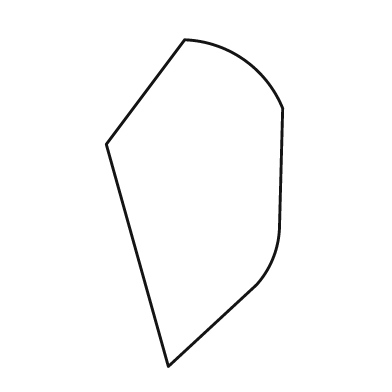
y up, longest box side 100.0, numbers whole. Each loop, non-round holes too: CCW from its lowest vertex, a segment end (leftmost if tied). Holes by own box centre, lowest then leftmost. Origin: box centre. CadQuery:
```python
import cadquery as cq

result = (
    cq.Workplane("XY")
    .moveTo(-8.0, -50.0)
    .lineTo(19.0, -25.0)
    .threePointArc((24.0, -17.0), (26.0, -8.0))
    .lineTo(27.0, 29.0)
    .threePointArc((15.0, 44.0), (-3.0, 50.0))
    .lineTo(-27.0, 18.0)
    .close()
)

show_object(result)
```